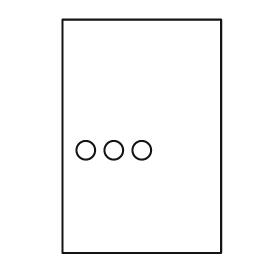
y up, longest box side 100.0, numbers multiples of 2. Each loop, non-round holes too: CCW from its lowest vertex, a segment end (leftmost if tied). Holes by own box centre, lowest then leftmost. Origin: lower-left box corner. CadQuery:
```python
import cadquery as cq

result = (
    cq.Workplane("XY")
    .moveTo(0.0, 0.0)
    .lineTo(68.0, 0.0)
    .lineTo(68.0, 100.0)
    .lineTo(0.0, 100.0)
    .close()
    .moveTo(10.0, 44.0)
    .circle(4.0)
    .moveTo(22.0, 44.0)
    .circle(4.0)
    .moveTo(34.0, 44.0)
    .circle(4.0)
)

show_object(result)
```